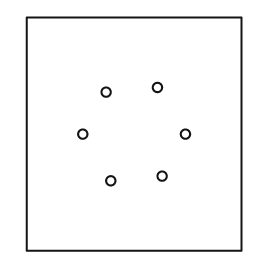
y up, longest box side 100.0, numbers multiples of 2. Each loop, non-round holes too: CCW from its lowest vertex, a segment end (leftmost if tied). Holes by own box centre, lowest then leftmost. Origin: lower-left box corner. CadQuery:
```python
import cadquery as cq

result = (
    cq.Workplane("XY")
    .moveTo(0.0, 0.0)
    .lineTo(92.0, 0.0)
    .lineTo(92.0, 100.0)
    .lineTo(0.0, 100.0)
    .close()
    .moveTo(36.0, 30.0)
    .circle(2.0)
    .moveTo(58.0, 32.0)
    .circle(2.0)
    .moveTo(24.0, 50.0)
    .circle(2.0)
    .moveTo(68.0, 50.0)
    .circle(2.0)
    .moveTo(34.0, 68.0)
    .circle(2.0)
    .moveTo(56.0, 70.0)
    .circle(2.0)
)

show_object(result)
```